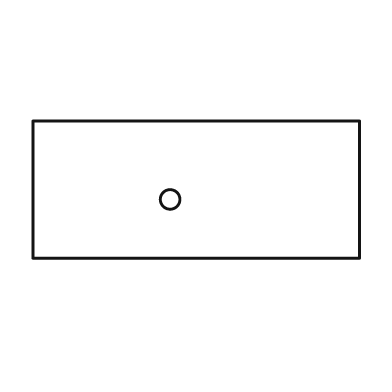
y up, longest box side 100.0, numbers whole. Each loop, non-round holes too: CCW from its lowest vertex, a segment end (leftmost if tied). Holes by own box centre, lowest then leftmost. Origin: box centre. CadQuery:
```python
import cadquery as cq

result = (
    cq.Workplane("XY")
    .moveTo(-50.0, -21.0)
    .lineTo(50.0, -21.0)
    .lineTo(50.0, 21.0)
    .lineTo(-50.0, 21.0)
    .close()
    .moveTo(-8.0, -3.0)
    .circle(3.0)
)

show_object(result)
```